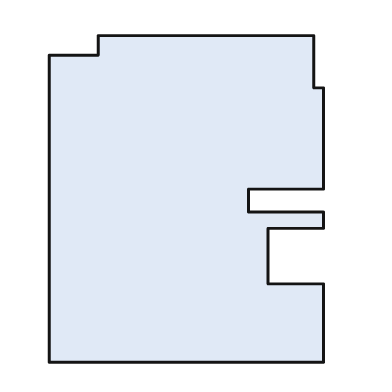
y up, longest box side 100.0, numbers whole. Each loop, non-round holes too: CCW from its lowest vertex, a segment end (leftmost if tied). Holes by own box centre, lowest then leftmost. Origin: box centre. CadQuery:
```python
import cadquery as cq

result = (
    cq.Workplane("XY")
    .moveTo(-42.0, -50.0)
    .lineTo(42.0, -50.0)
    .lineTo(42.0, -26.0)
    .lineTo(25.0, -26.0)
    .lineTo(25.0, -9.0)
    .lineTo(42.0, -9.0)
    .lineTo(42.0, -4.0)
    .lineTo(19.0, -4.0)
    .lineTo(19.0, 3.0)
    .lineTo(42.0, 3.0)
    .lineTo(42.0, 34.0)
    .lineTo(39.0, 34.0)
    .lineTo(39.0, 50.0)
    .lineTo(-27.0, 50.0)
    .lineTo(-27.0, 44.0)
    .lineTo(-42.0, 44.0)
    .close()
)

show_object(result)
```